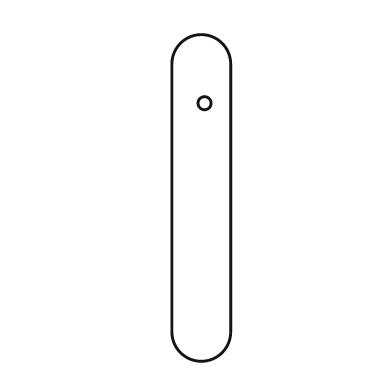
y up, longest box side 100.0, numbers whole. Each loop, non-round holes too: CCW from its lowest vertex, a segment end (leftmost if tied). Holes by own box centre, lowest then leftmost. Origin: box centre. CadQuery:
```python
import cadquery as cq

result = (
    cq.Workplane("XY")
    .moveTo(-9.0, -41.0)
    .threePointArc((0.0, -50.0), (9.0, -41.0))
    .lineTo(9.0, 41.0)
    .threePointArc((0.0, 50.0), (-9.0, 41.0))
    .close()
    .moveTo(1.0, 29.0)
    .circle(2.0)
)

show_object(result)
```